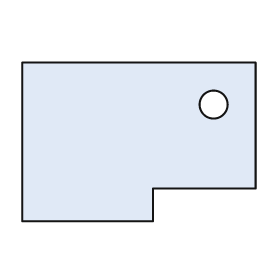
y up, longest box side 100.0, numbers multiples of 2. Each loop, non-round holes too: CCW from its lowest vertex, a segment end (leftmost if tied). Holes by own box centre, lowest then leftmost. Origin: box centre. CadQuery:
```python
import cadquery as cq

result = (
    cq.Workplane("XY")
    .moveTo(-50.0, -34.0)
    .lineTo(6.0, -34.0)
    .lineTo(6.0, -20.0)
    .lineTo(50.0, -20.0)
    .lineTo(50.0, 34.0)
    .lineTo(-50.0, 34.0)
    .close()
    .moveTo(32.0, 16.0)
    .circle(6.0)
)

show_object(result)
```